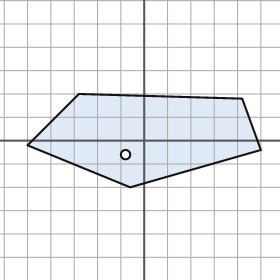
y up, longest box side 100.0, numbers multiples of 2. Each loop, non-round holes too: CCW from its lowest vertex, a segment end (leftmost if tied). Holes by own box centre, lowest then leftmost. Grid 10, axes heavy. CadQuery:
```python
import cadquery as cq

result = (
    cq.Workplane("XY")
    .moveTo(-6.0, -20.0)
    .lineTo(50.0, -4.0)
    .lineTo(42.0, 18.0)
    .lineTo(-28.0, 20.0)
    .lineTo(-50.0, -2.0)
    .close()
    .moveTo(-8.0, -6.0)
    .circle(2.0)
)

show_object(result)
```